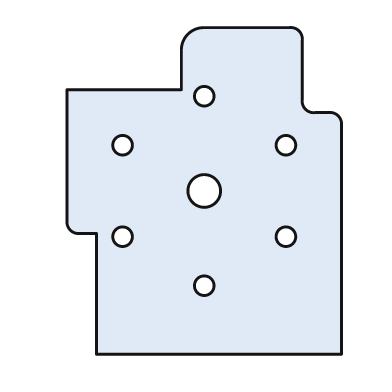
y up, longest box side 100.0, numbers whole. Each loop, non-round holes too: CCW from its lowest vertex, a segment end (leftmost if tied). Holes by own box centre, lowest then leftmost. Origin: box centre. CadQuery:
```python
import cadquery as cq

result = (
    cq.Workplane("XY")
    .moveTo(-33.0, -50.0)
    .lineTo(42.0, -50.0)
    .lineTo(42.0, 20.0)
    .threePointArc((41.0, 23.0), (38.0, 24.0))
    .lineTo(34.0, 24.0)
    .threePointArc((31.0, 25.0), (30.0, 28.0))
    .lineTo(30.0, 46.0)
    .threePointArc((29.0, 49.0), (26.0, 50.0))
    .lineTo(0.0, 50.0)
    .threePointArc((-5.0, 48.0), (-7.0, 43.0))
    .lineTo(-7.0, 31.0)
    .lineTo(-42.0, 31.0)
    .lineTo(-42.0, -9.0)
    .threePointArc((-41.0, -12.0), (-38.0, -13.0))
    .lineTo(-33.0, -13.0)
    .close()
    .moveTo(0.0, -29.0)
    .circle(3.0)
    .moveTo(-25.0, -14.0)
    .circle(3.0)
    .moveTo(25.0, -14.0)
    .circle(3.0)
    .moveTo(0.0, 0.0)
    .circle(5.0)
    .moveTo(-25.0, 14.0)
    .circle(3.0)
    .moveTo(25.0, 14.0)
    .circle(3.0)
    .moveTo(0.0, 29.0)
    .circle(3.0)
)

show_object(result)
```